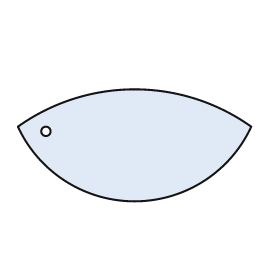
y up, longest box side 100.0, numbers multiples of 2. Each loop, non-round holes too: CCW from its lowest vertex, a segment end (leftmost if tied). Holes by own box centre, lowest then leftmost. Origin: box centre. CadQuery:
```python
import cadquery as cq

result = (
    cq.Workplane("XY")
    .moveTo(-50.0, 8.0)
    .threePointArc((0.0, -24.0), (50.0, 8.0))
    .threePointArc((0.0, 24.0), (-50.0, 8.0))
    .close()
    .moveTo(-38.0, 6.0)
    .circle(2.0)
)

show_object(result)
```